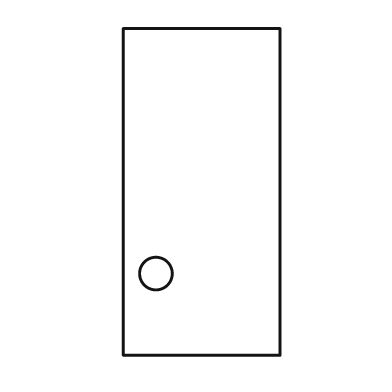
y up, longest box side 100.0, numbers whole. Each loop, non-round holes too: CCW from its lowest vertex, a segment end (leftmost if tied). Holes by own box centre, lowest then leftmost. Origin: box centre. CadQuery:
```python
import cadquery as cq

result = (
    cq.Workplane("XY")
    .moveTo(-24.0, -50.0)
    .lineTo(24.0, -50.0)
    .lineTo(24.0, 50.0)
    .lineTo(-24.0, 50.0)
    .close()
    .moveTo(-14.0, -25.0)
    .circle(5.0)
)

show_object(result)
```